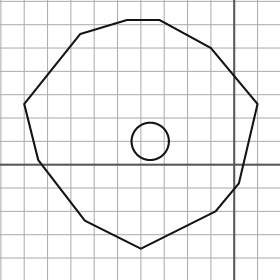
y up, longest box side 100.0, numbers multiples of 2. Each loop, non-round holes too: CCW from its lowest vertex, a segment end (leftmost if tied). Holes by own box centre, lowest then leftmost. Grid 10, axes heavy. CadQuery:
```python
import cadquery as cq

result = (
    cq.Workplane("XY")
    .moveTo(-40.0, -36.0)
    .lineTo(-8.0, -20.0)
    .lineTo(2.0, -8.0)
    .lineTo(10.0, 26.0)
    .lineTo(-10.0, 50.0)
    .lineTo(-32.0, 62.0)
    .lineTo(-46.0, 62.0)
    .lineTo(-66.0, 56.0)
    .lineTo(-90.0, 26.0)
    .lineTo(-84.0, 2.0)
    .lineTo(-64.0, -24.0)
    .close()
    .moveTo(-36.0, 10.0)
    .circle(8.0)
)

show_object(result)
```